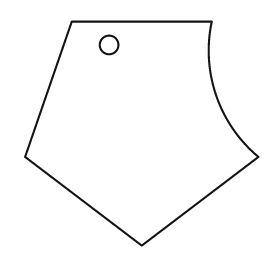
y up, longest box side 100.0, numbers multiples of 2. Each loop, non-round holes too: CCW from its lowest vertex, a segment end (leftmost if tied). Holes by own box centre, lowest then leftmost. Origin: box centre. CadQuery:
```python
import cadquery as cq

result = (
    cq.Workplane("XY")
    .moveTo(0.0, -48.0)
    .lineTo(50.0, -10.0)
    .threePointArc((32.0, 16.0), (30.0, 48.0))
    .lineTo(-30.0, 48.0)
    .lineTo(-50.0, -10.0)
    .close()
    .moveTo(-14.0, 38.0)
    .circle(4.0)
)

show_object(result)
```